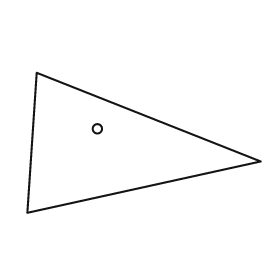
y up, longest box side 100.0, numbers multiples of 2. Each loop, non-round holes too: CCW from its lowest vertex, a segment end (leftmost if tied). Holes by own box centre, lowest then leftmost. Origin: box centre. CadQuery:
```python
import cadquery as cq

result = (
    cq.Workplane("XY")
    .moveTo(-50.0, -30.0)
    .lineTo(50.0, -8.0)
    .lineTo(-46.0, 30.0)
    .close()
    .moveTo(-20.0, 6.0)
    .circle(2.0)
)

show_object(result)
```